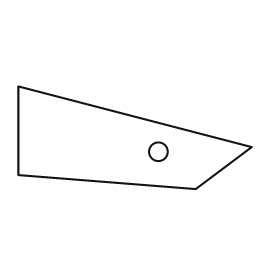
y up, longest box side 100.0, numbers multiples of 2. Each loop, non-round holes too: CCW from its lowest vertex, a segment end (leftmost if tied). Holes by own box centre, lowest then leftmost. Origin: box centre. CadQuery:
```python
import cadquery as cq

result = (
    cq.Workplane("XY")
    .moveTo(26.0, -22.0)
    .lineTo(50.0, -4.0)
    .lineTo(-50.0, 22.0)
    .lineTo(-50.0, -16.0)
    .close()
    .moveTo(10.0, -6.0)
    .circle(4.0)
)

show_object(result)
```